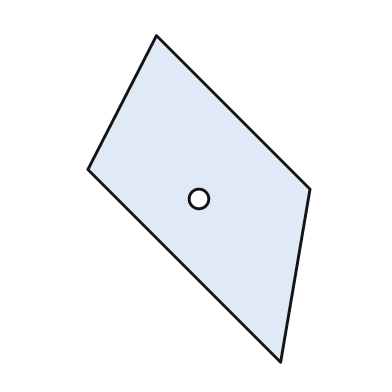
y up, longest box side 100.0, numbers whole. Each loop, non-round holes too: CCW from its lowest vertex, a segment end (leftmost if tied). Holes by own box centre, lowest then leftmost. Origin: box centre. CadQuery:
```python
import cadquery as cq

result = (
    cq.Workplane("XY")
    .moveTo(25.0, -50.0)
    .lineTo(34.0, 3.0)
    .lineTo(-13.0, 50.0)
    .lineTo(-34.0, 9.0)
    .close()
    .moveTo(0.0, 0.0)
    .circle(3.0)
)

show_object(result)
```